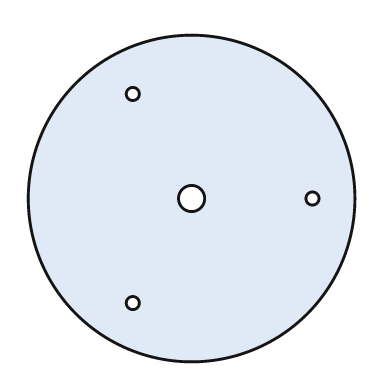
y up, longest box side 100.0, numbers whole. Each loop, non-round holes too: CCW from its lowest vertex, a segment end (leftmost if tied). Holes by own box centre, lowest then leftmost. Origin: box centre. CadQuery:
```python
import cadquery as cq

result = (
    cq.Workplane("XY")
    .moveTo(0.0, 0.0)
    .circle(50.0)
    .moveTo(-18.0, -32.0)
    .circle(2.0)
    .moveTo(0.0, 0.0)
    .circle(4.0)
    .moveTo(37.0, 0.0)
    .circle(2.0)
    .moveTo(-18.0, 32.0)
    .circle(2.0)
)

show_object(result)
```